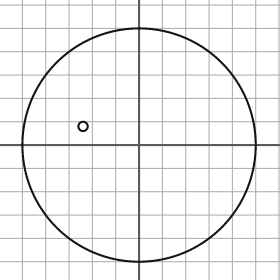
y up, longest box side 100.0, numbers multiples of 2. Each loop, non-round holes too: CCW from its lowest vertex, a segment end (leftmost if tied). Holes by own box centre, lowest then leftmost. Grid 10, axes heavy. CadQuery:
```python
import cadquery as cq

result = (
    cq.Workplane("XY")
    .moveTo(0.0, 0.0)
    .circle(50.0)
    .moveTo(-24.0, 8.0)
    .circle(2.0)
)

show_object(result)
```